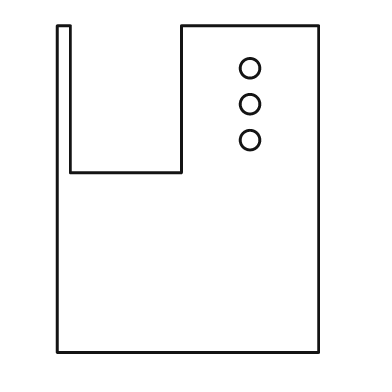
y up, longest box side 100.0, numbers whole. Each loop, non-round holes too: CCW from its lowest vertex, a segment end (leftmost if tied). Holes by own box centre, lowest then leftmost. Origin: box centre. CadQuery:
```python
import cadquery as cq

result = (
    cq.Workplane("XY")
    .moveTo(-40.0, -50.0)
    .lineTo(40.0, -50.0)
    .lineTo(40.0, 50.0)
    .lineTo(-2.0, 50.0)
    .lineTo(-2.0, 5.0)
    .lineTo(-36.0, 5.0)
    .lineTo(-36.0, 50.0)
    .lineTo(-40.0, 50.0)
    .close()
    .moveTo(19.0, 15.0)
    .circle(3.0)
    .moveTo(19.0, 26.0)
    .circle(3.0)
    .moveTo(19.0, 37.0)
    .circle(3.0)
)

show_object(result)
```